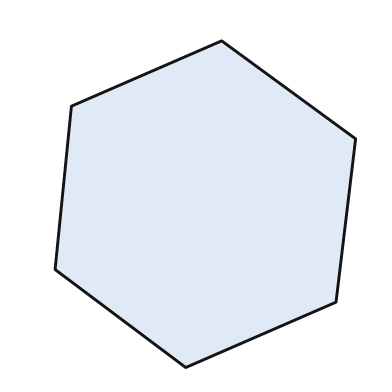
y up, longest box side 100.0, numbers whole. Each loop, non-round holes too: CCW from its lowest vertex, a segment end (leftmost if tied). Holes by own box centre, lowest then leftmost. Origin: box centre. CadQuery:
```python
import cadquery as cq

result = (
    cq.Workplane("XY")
    .moveTo(-6.0, -50.0)
    .lineTo(40.0, -30.0)
    .lineTo(46.0, 20.0)
    .lineTo(5.0, 50.0)
    .lineTo(-41.0, 30.0)
    .lineTo(-46.0, -20.0)
    .close()
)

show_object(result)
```